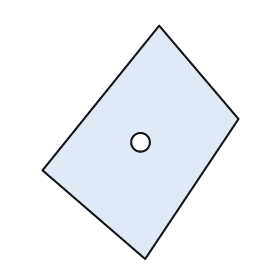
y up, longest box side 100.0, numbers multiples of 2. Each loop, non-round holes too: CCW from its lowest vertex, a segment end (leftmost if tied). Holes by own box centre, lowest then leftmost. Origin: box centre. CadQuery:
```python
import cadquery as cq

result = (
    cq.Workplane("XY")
    .moveTo(2.0, -50.0)
    .lineTo(42.0, 10.0)
    .lineTo(8.0, 50.0)
    .lineTo(-42.0, -12.0)
    .close()
    .moveTo(0.0, 0.0)
    .circle(4.0)
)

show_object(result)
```